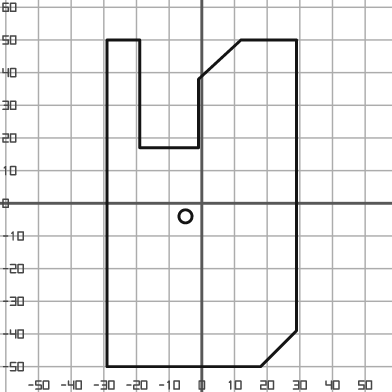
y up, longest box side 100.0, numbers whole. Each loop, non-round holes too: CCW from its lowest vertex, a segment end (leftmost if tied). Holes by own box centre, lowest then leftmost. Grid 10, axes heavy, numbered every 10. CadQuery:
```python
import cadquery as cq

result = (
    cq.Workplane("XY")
    .moveTo(-29.0, -50.0)
    .lineTo(18.0, -50.0)
    .lineTo(29.0, -39.0)
    .lineTo(29.0, 50.0)
    .lineTo(12.0, 50.0)
    .lineTo(-1.0, 38.0)
    .lineTo(-1.0, 17.0)
    .lineTo(-19.0, 17.0)
    .lineTo(-19.0, 50.0)
    .lineTo(-29.0, 50.0)
    .close()
    .moveTo(-5.0, -4.0)
    .circle(2.0)
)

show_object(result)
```